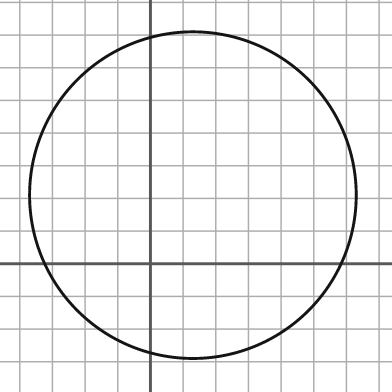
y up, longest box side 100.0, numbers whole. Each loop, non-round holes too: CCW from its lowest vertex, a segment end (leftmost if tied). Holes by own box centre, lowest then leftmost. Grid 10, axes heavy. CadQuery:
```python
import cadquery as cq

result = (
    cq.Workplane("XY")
    .moveTo(13.0, 21.0)
    .circle(50.0)
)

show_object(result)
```